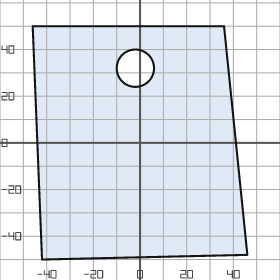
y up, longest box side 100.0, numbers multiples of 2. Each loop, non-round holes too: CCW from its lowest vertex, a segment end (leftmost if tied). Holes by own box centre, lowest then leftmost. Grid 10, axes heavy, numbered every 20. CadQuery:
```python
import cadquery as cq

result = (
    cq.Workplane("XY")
    .moveTo(-42.0, -50.0)
    .lineTo(46.0, -48.0)
    .lineTo(36.0, 50.0)
    .lineTo(-46.0, 50.0)
    .close()
    .moveTo(-2.0, 32.0)
    .circle(8.0)
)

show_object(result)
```